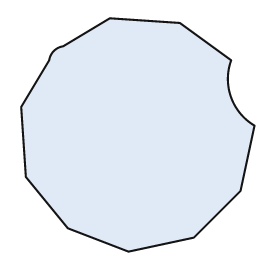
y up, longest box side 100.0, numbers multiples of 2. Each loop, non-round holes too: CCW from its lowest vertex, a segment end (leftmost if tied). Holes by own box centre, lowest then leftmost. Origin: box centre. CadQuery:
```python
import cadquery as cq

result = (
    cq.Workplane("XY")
    .moveTo(-4.0, -50.0)
    .lineTo(24.0, -44.0)
    .lineTo(44.0, -24.0)
    .lineTo(50.0, 4.0)
    .threePointArc((40.0, 16.0), (40.0, 32.0))
    .lineTo(18.0, 48.0)
    .lineTo(-12.0, 50.0)
    .lineTo(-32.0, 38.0)
    .threePointArc((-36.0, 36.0), (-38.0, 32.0))
    .lineTo(-50.0, 12.0)
    .lineTo(-48.0, -18.0)
    .lineTo(-30.0, -40.0)
    .close()
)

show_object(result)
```